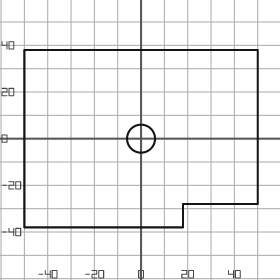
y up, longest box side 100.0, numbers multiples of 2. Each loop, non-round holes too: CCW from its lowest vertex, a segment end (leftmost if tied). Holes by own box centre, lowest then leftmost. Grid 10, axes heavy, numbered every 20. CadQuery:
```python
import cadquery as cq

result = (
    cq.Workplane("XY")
    .moveTo(-50.0, -38.0)
    .lineTo(18.0, -38.0)
    .lineTo(18.0, -28.0)
    .lineTo(50.0, -28.0)
    .lineTo(50.0, 38.0)
    .lineTo(-50.0, 38.0)
    .close()
    .moveTo(0.0, 0.0)
    .circle(6.0)
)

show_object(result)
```